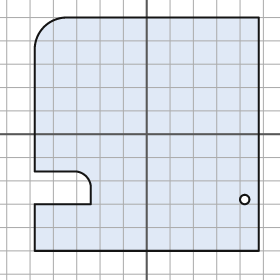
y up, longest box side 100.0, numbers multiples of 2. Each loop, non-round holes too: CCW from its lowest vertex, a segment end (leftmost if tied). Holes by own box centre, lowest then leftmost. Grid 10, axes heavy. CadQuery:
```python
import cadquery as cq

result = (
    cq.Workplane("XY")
    .moveTo(-48.0, -50.0)
    .lineTo(48.0, -50.0)
    .lineTo(48.0, 50.0)
    .lineTo(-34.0, 50.0)
    .threePointArc((-44.0, 46.0), (-48.0, 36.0))
    .lineTo(-48.0, -16.0)
    .lineTo(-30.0, -16.0)
    .threePointArc((-26.0, -18.0), (-24.0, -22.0))
    .lineTo(-24.0, -30.0)
    .lineTo(-48.0, -30.0)
    .close()
    .moveTo(42.0, -28.0)
    .circle(2.0)
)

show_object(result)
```